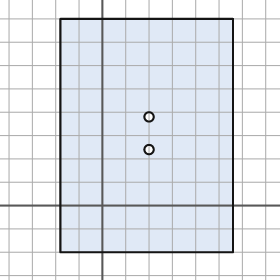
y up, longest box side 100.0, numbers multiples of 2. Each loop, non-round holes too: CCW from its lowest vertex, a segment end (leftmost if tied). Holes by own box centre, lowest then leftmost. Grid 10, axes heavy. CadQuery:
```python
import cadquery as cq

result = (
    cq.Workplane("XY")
    .moveTo(-18.0, -20.0)
    .lineTo(56.0, -20.0)
    .lineTo(56.0, 80.0)
    .lineTo(-18.0, 80.0)
    .close()
    .moveTo(20.0, 24.0)
    .circle(2.0)
    .moveTo(20.0, 38.0)
    .circle(2.0)
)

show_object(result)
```